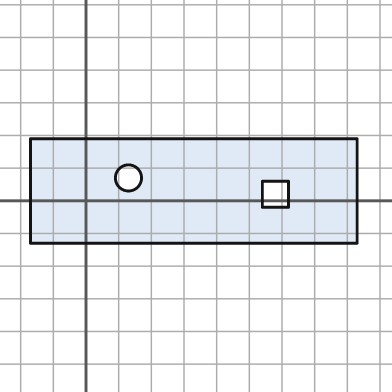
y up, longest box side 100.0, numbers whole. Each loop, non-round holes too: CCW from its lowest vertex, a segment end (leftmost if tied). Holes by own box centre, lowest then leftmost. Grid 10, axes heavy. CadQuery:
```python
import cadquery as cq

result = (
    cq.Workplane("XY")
    .moveTo(-17.0, -13.0)
    .lineTo(83.0, -13.0)
    .lineTo(83.0, 19.0)
    .lineTo(-17.0, 19.0)
    .close()
    .moveTo(54.0, -2.0)
    .lineTo(62.0, -2.0)
    .lineTo(62.0, 6.0)
    .lineTo(54.0, 6.0)
    .close()
    .moveTo(13.0, 7.0)
    .circle(4.0)
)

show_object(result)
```